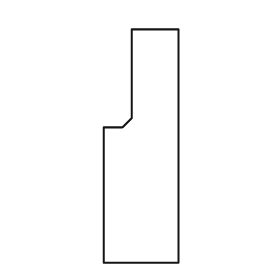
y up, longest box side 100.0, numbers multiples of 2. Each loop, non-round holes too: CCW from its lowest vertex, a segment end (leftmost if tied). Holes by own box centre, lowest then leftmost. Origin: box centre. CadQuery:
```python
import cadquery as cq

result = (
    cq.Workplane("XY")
    .moveTo(-16.0, -50.0)
    .lineTo(16.0, -50.0)
    .lineTo(16.0, 50.0)
    .lineTo(-4.0, 50.0)
    .lineTo(-4.0, 12.0)
    .lineTo(-8.0, 8.0)
    .lineTo(-16.0, 8.0)
    .close()
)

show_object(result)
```